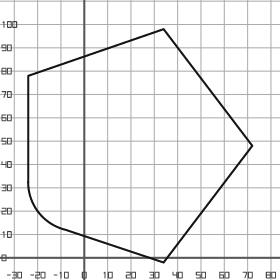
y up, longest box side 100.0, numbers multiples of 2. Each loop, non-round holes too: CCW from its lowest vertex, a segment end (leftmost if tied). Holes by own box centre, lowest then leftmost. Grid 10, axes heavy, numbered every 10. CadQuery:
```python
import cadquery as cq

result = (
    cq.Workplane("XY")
    .moveTo(34.0, -2.0)
    .lineTo(72.0, 48.0)
    .lineTo(34.0, 98.0)
    .lineTo(-24.0, 78.0)
    .lineTo(-24.0, 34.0)
    .threePointArc((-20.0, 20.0), (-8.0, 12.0))
    .close()
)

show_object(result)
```